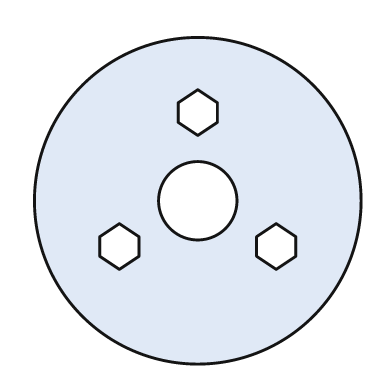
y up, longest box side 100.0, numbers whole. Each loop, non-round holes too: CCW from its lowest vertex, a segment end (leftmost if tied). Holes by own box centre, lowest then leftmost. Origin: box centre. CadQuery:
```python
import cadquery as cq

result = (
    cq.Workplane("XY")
    .moveTo(0.0, 0.0)
    .circle(50.0)
    .moveTo(-24.0, -21.0)
    .lineTo(-18.0, -17.0)
    .lineTo(-18.0, -11.0)
    .lineTo(-24.0, -7.0)
    .lineTo(-30.0, -11.0)
    .lineTo(-30.0, -17.0)
    .close()
    .moveTo(24.0, -21.0)
    .lineTo(30.0, -17.0)
    .lineTo(30.0, -11.0)
    .lineTo(24.0, -7.0)
    .lineTo(18.0, -11.0)
    .lineTo(18.0, -17.0)
    .close()
    .moveTo(0.0, 0.0)
    .circle(12.0)
    .moveTo(0.0, 20.0)
    .lineTo(6.0, 24.0)
    .lineTo(6.0, 30.0)
    .lineTo(0.0, 34.0)
    .lineTo(-6.0, 30.0)
    .lineTo(-6.0, 24.0)
    .close()
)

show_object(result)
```